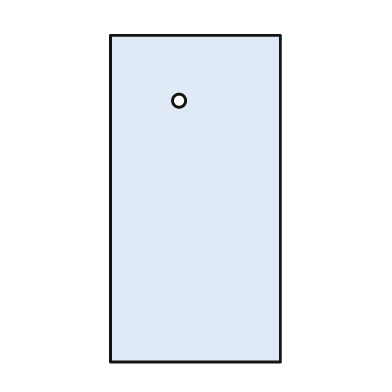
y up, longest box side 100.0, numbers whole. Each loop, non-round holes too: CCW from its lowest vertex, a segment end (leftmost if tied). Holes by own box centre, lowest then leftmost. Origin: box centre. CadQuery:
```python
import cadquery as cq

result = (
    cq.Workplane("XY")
    .moveTo(-26.0, -50.0)
    .lineTo(26.0, -50.0)
    .lineTo(26.0, 50.0)
    .lineTo(-26.0, 50.0)
    .close()
    .moveTo(-5.0, 30.0)
    .circle(2.0)
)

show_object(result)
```